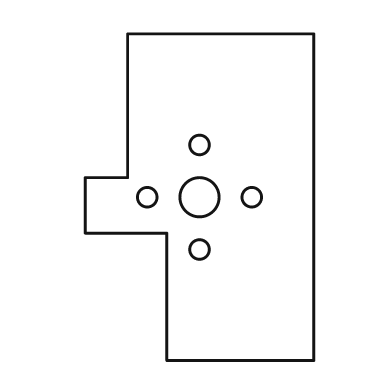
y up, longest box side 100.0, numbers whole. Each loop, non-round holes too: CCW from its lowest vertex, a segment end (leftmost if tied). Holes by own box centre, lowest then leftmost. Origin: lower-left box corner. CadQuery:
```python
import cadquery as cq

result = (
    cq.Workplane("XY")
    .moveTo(25.0, 0.0)
    .lineTo(70.0, 0.0)
    .lineTo(70.0, 100.0)
    .lineTo(13.0, 100.0)
    .lineTo(13.0, 56.0)
    .lineTo(0.0, 56.0)
    .lineTo(0.0, 39.0)
    .lineTo(25.0, 39.0)
    .close()
    .moveTo(35.0, 34.0)
    .circle(3.0)
    .moveTo(19.0, 50.0)
    .circle(3.0)
    .moveTo(35.0, 50.0)
    .circle(6.0)
    .moveTo(51.0, 50.0)
    .circle(3.0)
    .moveTo(35.0, 66.0)
    .circle(3.0)
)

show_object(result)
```